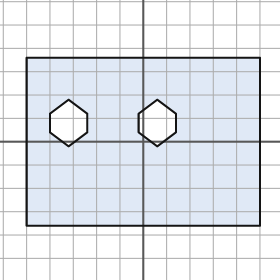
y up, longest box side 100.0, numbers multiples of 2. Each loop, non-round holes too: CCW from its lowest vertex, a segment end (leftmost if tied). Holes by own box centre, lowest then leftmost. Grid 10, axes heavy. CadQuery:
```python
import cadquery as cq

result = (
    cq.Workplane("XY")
    .moveTo(-50.0, -36.0)
    .lineTo(50.0, -36.0)
    .lineTo(50.0, 36.0)
    .lineTo(-50.0, 36.0)
    .close()
    .moveTo(-32.0, -2.0)
    .lineTo(-24.0, 4.0)
    .lineTo(-24.0, 12.0)
    .lineTo(-32.0, 18.0)
    .lineTo(-40.0, 12.0)
    .lineTo(-40.0, 4.0)
    .close()
    .moveTo(6.0, -2.0)
    .lineTo(14.0, 4.0)
    .lineTo(14.0, 12.0)
    .lineTo(6.0, 18.0)
    .lineTo(-2.0, 12.0)
    .lineTo(-2.0, 4.0)
    .close()
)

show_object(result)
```